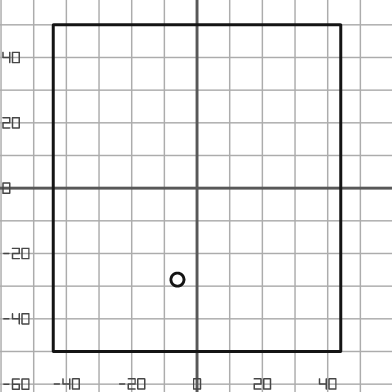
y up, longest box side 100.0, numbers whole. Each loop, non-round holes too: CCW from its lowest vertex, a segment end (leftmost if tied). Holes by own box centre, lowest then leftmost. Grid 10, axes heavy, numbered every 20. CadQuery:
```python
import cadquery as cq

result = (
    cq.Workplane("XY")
    .moveTo(-44.0, -50.0)
    .lineTo(44.0, -50.0)
    .lineTo(44.0, 50.0)
    .lineTo(-44.0, 50.0)
    .close()
    .moveTo(-6.0, -28.0)
    .circle(2.0)
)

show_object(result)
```